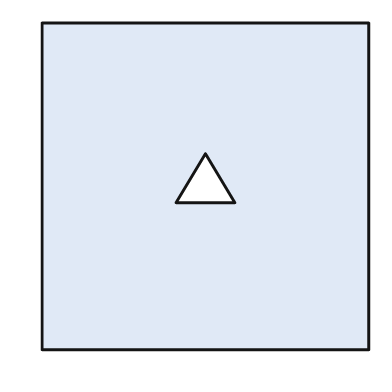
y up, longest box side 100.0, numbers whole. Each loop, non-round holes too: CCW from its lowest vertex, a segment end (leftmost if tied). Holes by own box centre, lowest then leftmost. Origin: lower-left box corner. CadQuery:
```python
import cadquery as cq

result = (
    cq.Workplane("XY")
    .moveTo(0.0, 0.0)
    .lineTo(100.0, 0.0)
    .lineTo(100.0, 100.0)
    .lineTo(0.0, 100.0)
    .close()
    .moveTo(41.0, 45.0)
    .lineTo(59.0, 45.0)
    .lineTo(50.0, 60.0)
    .close()
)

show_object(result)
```